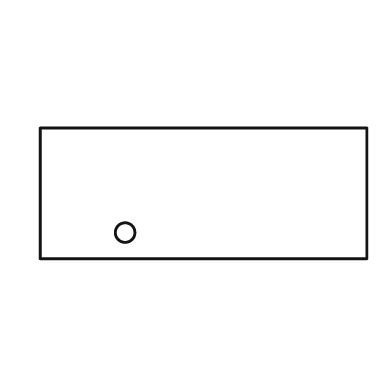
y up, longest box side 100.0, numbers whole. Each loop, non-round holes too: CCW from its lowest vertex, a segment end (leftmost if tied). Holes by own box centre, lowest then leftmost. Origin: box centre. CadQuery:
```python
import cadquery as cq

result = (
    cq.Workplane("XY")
    .moveTo(-50.0, -20.0)
    .lineTo(50.0, -20.0)
    .lineTo(50.0, 20.0)
    .lineTo(-50.0, 20.0)
    .close()
    .moveTo(-24.0, -12.0)
    .circle(3.0)
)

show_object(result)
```